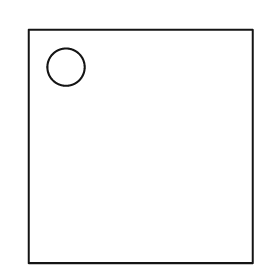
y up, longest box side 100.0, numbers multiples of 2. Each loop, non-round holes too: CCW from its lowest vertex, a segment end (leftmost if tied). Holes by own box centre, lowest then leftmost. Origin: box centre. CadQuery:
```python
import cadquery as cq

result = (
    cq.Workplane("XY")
    .moveTo(-48.0, -50.0)
    .lineTo(48.0, -50.0)
    .lineTo(48.0, 50.0)
    .lineTo(-48.0, 50.0)
    .close()
    .moveTo(-32.0, 34.0)
    .circle(8.0)
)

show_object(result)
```